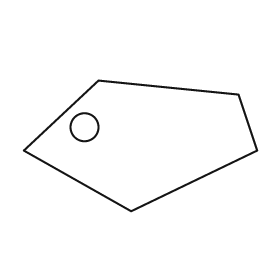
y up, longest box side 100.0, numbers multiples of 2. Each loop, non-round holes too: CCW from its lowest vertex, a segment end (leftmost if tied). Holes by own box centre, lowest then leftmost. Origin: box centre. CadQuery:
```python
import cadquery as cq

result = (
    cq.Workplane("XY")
    .moveTo(-4.0, -28.0)
    .lineTo(50.0, -2.0)
    .lineTo(42.0, 22.0)
    .lineTo(-18.0, 28.0)
    .lineTo(-50.0, -2.0)
    .close()
    .moveTo(-24.0, 8.0)
    .circle(6.0)
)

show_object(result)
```